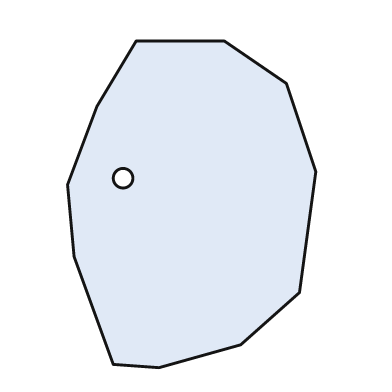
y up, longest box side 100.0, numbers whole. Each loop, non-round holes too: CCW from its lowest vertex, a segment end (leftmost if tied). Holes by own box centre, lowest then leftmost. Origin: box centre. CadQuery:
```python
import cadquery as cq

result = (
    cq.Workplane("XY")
    .moveTo(-10.0, -50.0)
    .lineTo(15.0, -43.0)
    .lineTo(33.0, -27.0)
    .lineTo(38.0, 10.0)
    .lineTo(29.0, 37.0)
    .lineTo(10.0, 50.0)
    .lineTo(-17.0, 50.0)
    .lineTo(-29.0, 30.0)
    .lineTo(-38.0, 6.0)
    .lineTo(-36.0, -16.0)
    .lineTo(-24.0, -49.0)
    .close()
    .moveTo(-21.0, 8.0)
    .circle(3.0)
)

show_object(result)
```